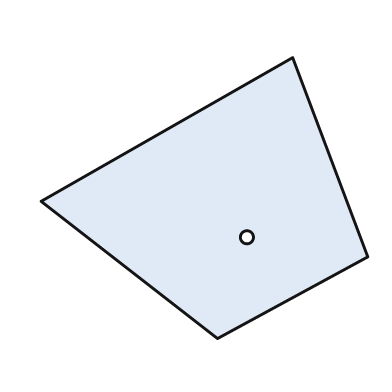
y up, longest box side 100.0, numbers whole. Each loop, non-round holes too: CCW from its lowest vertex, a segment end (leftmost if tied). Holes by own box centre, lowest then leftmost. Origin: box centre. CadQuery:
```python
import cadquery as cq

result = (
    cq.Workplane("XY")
    .moveTo(4.0, -43.0)
    .lineTo(50.0, -18.0)
    .lineTo(27.0, 43.0)
    .lineTo(-50.0, -1.0)
    .close()
    .moveTo(13.0, -12.0)
    .circle(2.0)
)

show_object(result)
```